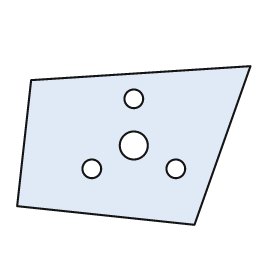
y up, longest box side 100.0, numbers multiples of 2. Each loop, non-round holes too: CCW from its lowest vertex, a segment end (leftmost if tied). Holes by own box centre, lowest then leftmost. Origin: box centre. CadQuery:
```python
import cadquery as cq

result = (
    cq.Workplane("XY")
    .moveTo(26.0, -34.0)
    .lineTo(50.0, 34.0)
    .lineTo(-44.0, 28.0)
    .lineTo(-50.0, -26.0)
    .close()
    .moveTo(-18.0, -10.0)
    .circle(4.0)
    .moveTo(18.0, -10.0)
    .circle(4.0)
    .moveTo(0.0, 0.0)
    .circle(6.0)
    .moveTo(0.0, 20.0)
    .circle(4.0)
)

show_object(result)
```